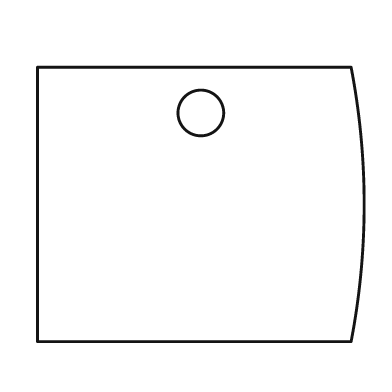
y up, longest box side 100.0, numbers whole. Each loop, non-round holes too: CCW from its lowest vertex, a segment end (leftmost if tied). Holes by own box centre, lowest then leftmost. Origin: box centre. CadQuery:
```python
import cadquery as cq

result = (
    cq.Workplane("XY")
    .moveTo(-50.0, -42.0)
    .lineTo(46.0, -42.0)
    .threePointArc((50.0, 0.0), (46.0, 42.0))
    .lineTo(-50.0, 42.0)
    .close()
    .moveTo(0.0, 28.0)
    .circle(7.0)
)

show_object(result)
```